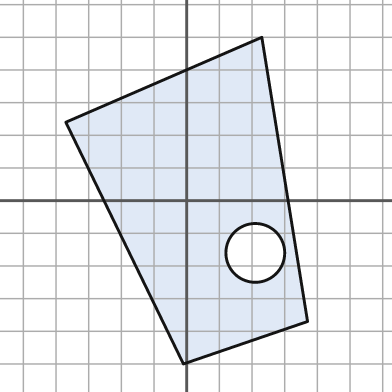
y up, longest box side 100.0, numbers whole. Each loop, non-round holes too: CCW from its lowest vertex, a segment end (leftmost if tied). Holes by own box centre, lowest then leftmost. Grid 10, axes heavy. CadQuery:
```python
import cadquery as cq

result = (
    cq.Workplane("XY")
    .moveTo(-1.0, -50.0)
    .lineTo(37.0, -37.0)
    .lineTo(23.0, 50.0)
    .lineTo(-37.0, 24.0)
    .close()
    .moveTo(21.0, -16.0)
    .circle(9.0)
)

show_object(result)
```